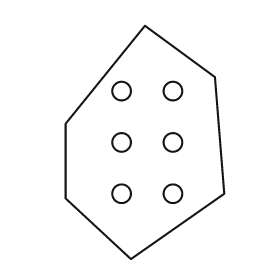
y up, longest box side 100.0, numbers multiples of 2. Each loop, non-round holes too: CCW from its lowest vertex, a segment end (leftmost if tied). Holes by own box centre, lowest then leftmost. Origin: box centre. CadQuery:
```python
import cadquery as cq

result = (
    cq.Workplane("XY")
    .moveTo(-6.0, -50.0)
    .lineTo(34.0, -22.0)
    .lineTo(30.0, 28.0)
    .lineTo(0.0, 50.0)
    .lineTo(-34.0, 8.0)
    .lineTo(-34.0, -24.0)
    .close()
    .moveTo(-10.0, -22.0)
    .circle(4.0)
    .moveTo(12.0, -22.0)
    .circle(4.0)
    .moveTo(-10.0, 0.0)
    .circle(4.0)
    .moveTo(12.0, 0.0)
    .circle(4.0)
    .moveTo(-10.0, 22.0)
    .circle(4.0)
    .moveTo(12.0, 22.0)
    .circle(4.0)
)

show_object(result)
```